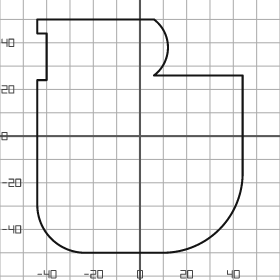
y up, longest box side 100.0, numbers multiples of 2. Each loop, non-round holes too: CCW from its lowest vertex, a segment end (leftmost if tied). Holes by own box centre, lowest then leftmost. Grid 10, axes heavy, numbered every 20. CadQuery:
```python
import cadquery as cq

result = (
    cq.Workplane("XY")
    .moveTo(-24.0, -50.0)
    .lineTo(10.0, -50.0)
    .threePointArc((34.0, -40.0), (44.0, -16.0))
    .lineTo(44.0, 26.0)
    .lineTo(6.0, 26.0)
    .threePointArc((12.0, 38.0), (6.0, 50.0))
    .lineTo(-44.0, 50.0)
    .lineTo(-44.0, 44.0)
    .lineTo(-40.0, 44.0)
    .lineTo(-40.0, 24.0)
    .lineTo(-44.0, 24.0)
    .lineTo(-44.0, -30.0)
    .threePointArc((-38.0, -44.0), (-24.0, -50.0))
    .close()
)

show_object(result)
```